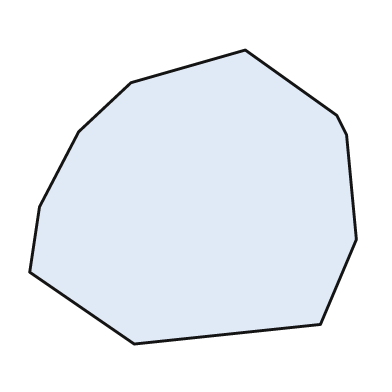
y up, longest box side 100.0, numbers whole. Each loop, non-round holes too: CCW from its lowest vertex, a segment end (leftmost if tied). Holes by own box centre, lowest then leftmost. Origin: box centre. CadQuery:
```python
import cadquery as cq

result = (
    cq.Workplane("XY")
    .moveTo(-18.0, -45.0)
    .lineTo(39.0, -39.0)
    .lineTo(50.0, -13.0)
    .lineTo(47.0, 19.0)
    .lineTo(44.0, 25.0)
    .lineTo(16.0, 45.0)
    .lineTo(-19.0, 35.0)
    .lineTo(-35.0, 20.0)
    .lineTo(-47.0, -3.0)
    .lineTo(-50.0, -23.0)
    .close()
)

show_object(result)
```